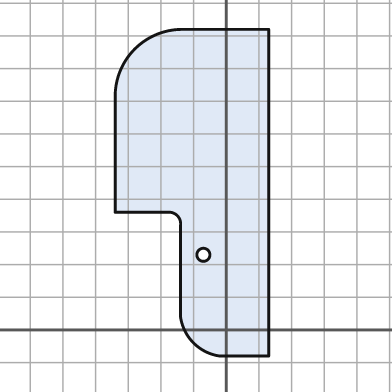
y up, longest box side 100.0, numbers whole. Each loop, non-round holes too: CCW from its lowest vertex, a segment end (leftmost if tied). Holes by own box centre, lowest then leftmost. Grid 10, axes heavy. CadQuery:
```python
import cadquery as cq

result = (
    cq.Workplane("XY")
    .moveTo(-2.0, -8.0)
    .lineTo(13.0, -8.0)
    .lineTo(13.0, 92.0)
    .lineTo(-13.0, 92.0)
    .threePointArc((-28.0, 86.0), (-34.0, 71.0))
    .lineTo(-34.0, 36.0)
    .lineTo(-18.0, 36.0)
    .threePointArc((-15.0, 35.0), (-14.0, 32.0))
    .lineTo(-14.0, 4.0)
    .threePointArc((-10.0, -4.0), (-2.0, -8.0))
    .close()
    .moveTo(-7.0, 23.0)
    .circle(2.0)
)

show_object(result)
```